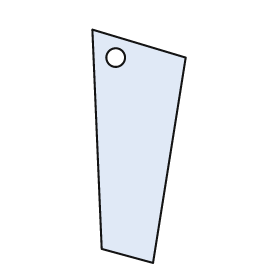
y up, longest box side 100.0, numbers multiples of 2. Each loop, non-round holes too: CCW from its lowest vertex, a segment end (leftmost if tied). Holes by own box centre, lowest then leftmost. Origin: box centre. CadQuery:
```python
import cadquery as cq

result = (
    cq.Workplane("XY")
    .moveTo(6.0, -50.0)
    .lineTo(20.0, 38.0)
    .lineTo(-20.0, 50.0)
    .lineTo(-16.0, -44.0)
    .close()
    .moveTo(-10.0, 38.0)
    .circle(4.0)
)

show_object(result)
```